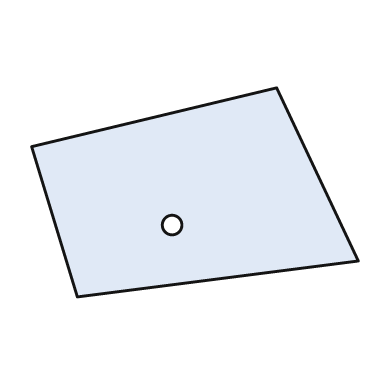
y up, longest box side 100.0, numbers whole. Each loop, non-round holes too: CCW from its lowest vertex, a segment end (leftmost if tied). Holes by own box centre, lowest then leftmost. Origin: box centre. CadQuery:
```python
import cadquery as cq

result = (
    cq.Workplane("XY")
    .moveTo(-36.0, -32.0)
    .lineTo(50.0, -21.0)
    .lineTo(25.0, 32.0)
    .lineTo(-50.0, 14.0)
    .close()
    .moveTo(-7.0, -10.0)
    .circle(3.0)
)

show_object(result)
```